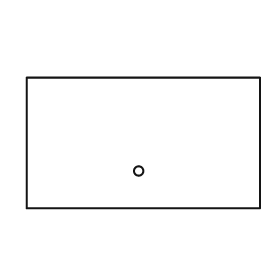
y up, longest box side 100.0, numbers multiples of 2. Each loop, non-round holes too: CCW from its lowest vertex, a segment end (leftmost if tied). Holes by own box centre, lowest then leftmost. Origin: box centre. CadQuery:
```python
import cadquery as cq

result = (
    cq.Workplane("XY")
    .moveTo(-50.0, -28.0)
    .lineTo(50.0, -28.0)
    .lineTo(50.0, 28.0)
    .lineTo(-50.0, 28.0)
    .close()
    .moveTo(-2.0, -12.0)
    .circle(2.0)
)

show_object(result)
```